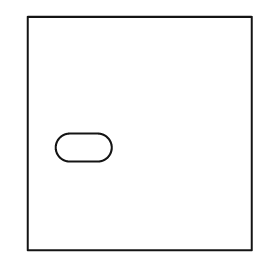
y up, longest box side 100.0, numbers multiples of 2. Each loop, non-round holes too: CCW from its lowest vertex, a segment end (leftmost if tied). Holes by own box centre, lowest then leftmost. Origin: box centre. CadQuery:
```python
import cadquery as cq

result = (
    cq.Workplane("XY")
    .moveTo(-48.0, -50.0)
    .lineTo(48.0, -50.0)
    .lineTo(48.0, 50.0)
    .lineTo(-48.0, 50.0)
    .close()
    .moveTo(-30.0, -12.0)
    .lineTo(-18.0, -12.0)
    .threePointArc((-12.0, -6.0), (-18.0, 0.0))
    .lineTo(-30.0, 0.0)
    .threePointArc((-36.0, -6.0), (-30.0, -12.0))
    .close()
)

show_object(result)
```